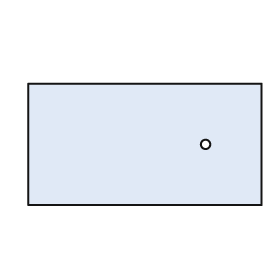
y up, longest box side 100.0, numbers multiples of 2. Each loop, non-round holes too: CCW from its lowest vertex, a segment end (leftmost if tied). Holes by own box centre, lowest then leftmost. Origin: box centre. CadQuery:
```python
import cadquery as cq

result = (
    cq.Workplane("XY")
    .moveTo(-50.0, -26.0)
    .lineTo(50.0, -26.0)
    .lineTo(50.0, 26.0)
    .lineTo(-50.0, 26.0)
    .close()
    .moveTo(26.0, 0.0)
    .circle(2.0)
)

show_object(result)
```